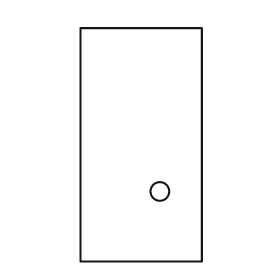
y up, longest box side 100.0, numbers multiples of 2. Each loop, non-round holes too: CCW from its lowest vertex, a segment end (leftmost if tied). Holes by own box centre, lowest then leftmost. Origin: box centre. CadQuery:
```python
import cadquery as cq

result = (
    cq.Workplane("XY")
    .moveTo(-26.0, -50.0)
    .lineTo(26.0, -50.0)
    .lineTo(26.0, 50.0)
    .lineTo(-26.0, 50.0)
    .close()
    .moveTo(8.0, -20.0)
    .circle(4.0)
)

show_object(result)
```